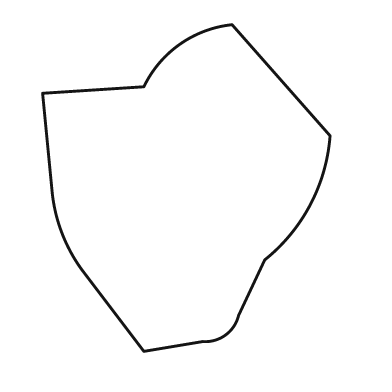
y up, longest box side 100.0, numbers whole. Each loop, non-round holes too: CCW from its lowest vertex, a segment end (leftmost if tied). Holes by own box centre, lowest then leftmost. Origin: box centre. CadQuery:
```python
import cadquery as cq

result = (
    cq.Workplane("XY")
    .moveTo(-13.0, -50.0)
    .lineTo(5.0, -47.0)
    .threePointArc((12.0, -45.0), (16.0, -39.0))
    .lineTo(24.0, -22.0)
    .threePointArc((38.0, -5.0), (44.0, 16.0))
    .lineTo(14.0, 50.0)
    .threePointArc((-2.0, 44.0), (-13.0, 31.0))
    .lineTo(-44.0, 29.0)
    .lineTo(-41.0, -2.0)
    .threePointArc((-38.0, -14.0), (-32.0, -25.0))
    .close()
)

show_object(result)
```